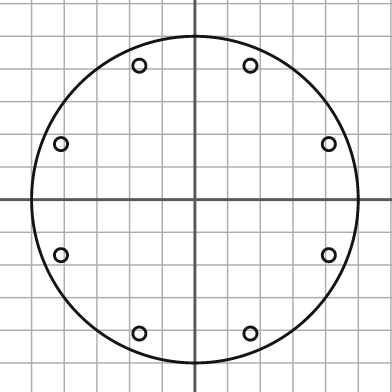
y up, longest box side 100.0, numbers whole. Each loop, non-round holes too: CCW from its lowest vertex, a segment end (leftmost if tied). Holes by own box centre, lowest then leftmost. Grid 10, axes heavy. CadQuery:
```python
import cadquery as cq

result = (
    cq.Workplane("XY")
    .moveTo(0.0, 0.0)
    .circle(50.0)
    .moveTo(-17.0, -41.0)
    .circle(2.0)
    .moveTo(17.0, -41.0)
    .circle(2.0)
    .moveTo(-41.0, -17.0)
    .circle(2.0)
    .moveTo(41.0, -17.0)
    .circle(2.0)
    .moveTo(-41.0, 17.0)
    .circle(2.0)
    .moveTo(41.0, 17.0)
    .circle(2.0)
    .moveTo(-17.0, 41.0)
    .circle(2.0)
    .moveTo(17.0, 41.0)
    .circle(2.0)
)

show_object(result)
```